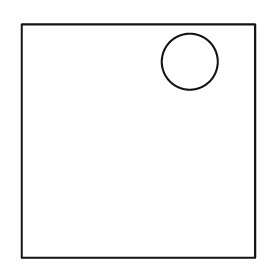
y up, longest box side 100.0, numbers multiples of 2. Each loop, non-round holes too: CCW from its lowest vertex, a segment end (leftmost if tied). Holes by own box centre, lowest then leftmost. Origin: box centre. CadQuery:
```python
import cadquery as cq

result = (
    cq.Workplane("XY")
    .moveTo(-50.0, -50.0)
    .lineTo(50.0, -50.0)
    .lineTo(50.0, 50.0)
    .lineTo(-50.0, 50.0)
    .close()
    .moveTo(22.0, 34.0)
    .circle(12.0)
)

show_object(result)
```